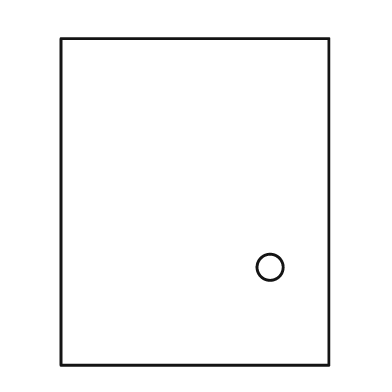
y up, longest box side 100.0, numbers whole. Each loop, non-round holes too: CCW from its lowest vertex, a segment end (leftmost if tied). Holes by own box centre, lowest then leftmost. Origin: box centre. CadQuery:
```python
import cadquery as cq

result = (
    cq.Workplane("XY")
    .moveTo(-41.0, -50.0)
    .lineTo(41.0, -50.0)
    .lineTo(41.0, 50.0)
    .lineTo(-41.0, 50.0)
    .close()
    .moveTo(23.0, -20.0)
    .circle(4.0)
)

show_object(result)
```